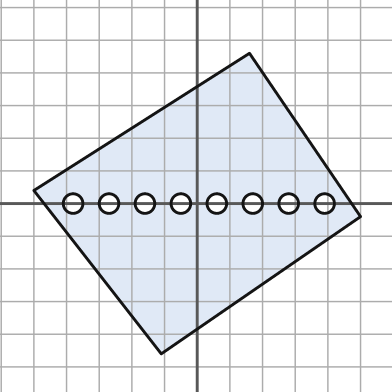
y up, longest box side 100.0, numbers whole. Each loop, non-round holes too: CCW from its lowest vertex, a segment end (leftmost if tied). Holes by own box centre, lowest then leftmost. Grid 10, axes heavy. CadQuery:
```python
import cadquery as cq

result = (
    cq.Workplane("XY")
    .moveTo(-11.0, -46.0)
    .lineTo(50.0, -4.0)
    .lineTo(16.0, 46.0)
    .lineTo(-50.0, 4.0)
    .close()
    .moveTo(-38.0, 0.0)
    .circle(3.0)
    .moveTo(-27.0, 0.0)
    .circle(3.0)
    .moveTo(-16.0, 0.0)
    .circle(3.0)
    .moveTo(-5.0, 0.0)
    .circle(3.0)
    .moveTo(6.0, 0.0)
    .circle(3.0)
    .moveTo(17.0, 0.0)
    .circle(3.0)
    .moveTo(28.0, 0.0)
    .circle(3.0)
    .moveTo(39.0, 0.0)
    .circle(3.0)
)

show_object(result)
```